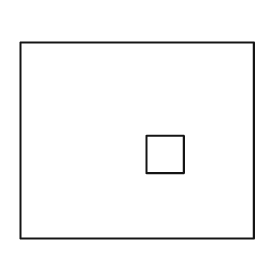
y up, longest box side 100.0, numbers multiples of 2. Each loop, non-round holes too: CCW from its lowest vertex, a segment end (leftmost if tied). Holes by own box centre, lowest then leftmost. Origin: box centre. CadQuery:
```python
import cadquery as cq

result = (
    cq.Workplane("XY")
    .moveTo(-50.0, -42.0)
    .lineTo(50.0, -42.0)
    .lineTo(50.0, 42.0)
    .lineTo(-50.0, 42.0)
    .close()
    .moveTo(4.0, -14.0)
    .lineTo(20.0, -14.0)
    .lineTo(20.0, 2.0)
    .lineTo(4.0, 2.0)
    .close()
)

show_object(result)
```